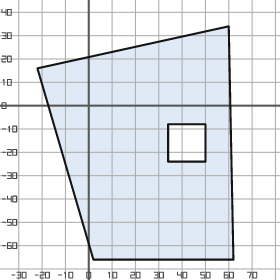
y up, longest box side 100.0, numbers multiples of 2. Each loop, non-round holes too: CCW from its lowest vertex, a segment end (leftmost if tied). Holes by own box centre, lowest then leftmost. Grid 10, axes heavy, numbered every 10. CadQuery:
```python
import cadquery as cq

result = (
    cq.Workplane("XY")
    .moveTo(2.0, -66.0)
    .lineTo(62.0, -66.0)
    .lineTo(60.0, 34.0)
    .lineTo(-22.0, 16.0)
    .close()
    .moveTo(34.0, -24.0)
    .lineTo(50.0, -24.0)
    .lineTo(50.0, -8.0)
    .lineTo(34.0, -8.0)
    .close()
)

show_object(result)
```